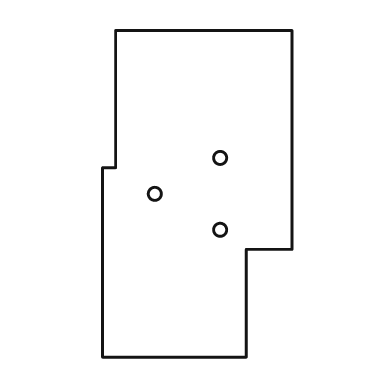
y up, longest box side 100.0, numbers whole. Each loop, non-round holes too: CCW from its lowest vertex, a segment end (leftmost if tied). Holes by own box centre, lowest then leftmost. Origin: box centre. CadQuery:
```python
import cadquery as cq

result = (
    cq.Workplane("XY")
    .moveTo(-29.0, -50.0)
    .lineTo(15.0, -50.0)
    .lineTo(15.0, -17.0)
    .lineTo(29.0, -17.0)
    .lineTo(29.0, 50.0)
    .lineTo(-25.0, 50.0)
    .lineTo(-25.0, 8.0)
    .lineTo(-29.0, 8.0)
    .close()
    .moveTo(7.0, -11.0)
    .circle(2.0)
    .moveTo(-13.0, 0.0)
    .circle(2.0)
    .moveTo(7.0, 11.0)
    .circle(2.0)
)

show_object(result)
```